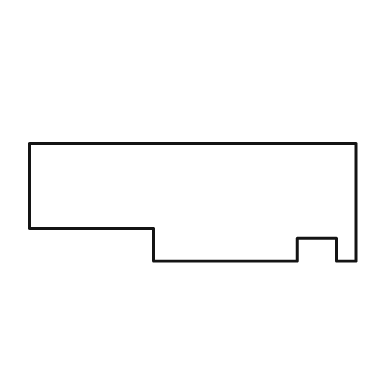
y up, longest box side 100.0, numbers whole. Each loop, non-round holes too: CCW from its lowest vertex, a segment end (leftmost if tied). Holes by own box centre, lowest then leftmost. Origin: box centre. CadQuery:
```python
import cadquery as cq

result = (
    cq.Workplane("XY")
    .moveTo(-12.0, -18.0)
    .lineTo(32.0, -18.0)
    .lineTo(32.0, -11.0)
    .lineTo(44.0, -11.0)
    .lineTo(44.0, -18.0)
    .lineTo(50.0, -18.0)
    .lineTo(50.0, 18.0)
    .lineTo(-50.0, 18.0)
    .lineTo(-50.0, -8.0)
    .lineTo(-12.0, -8.0)
    .close()
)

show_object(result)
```